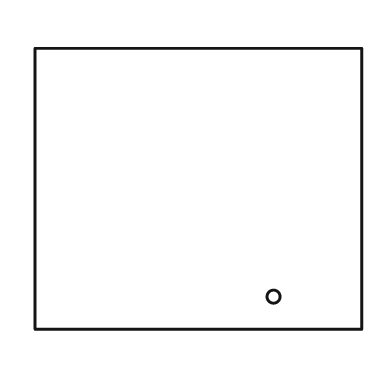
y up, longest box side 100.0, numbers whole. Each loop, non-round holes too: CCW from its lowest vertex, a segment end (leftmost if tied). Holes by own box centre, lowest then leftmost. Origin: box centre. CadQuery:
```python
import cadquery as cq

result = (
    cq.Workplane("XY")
    .moveTo(-50.0, -43.0)
    .lineTo(50.0, -43.0)
    .lineTo(50.0, 43.0)
    .lineTo(-50.0, 43.0)
    .close()
    .moveTo(23.0, -33.0)
    .circle(2.0)
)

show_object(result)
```